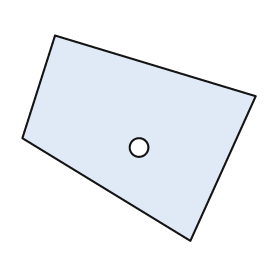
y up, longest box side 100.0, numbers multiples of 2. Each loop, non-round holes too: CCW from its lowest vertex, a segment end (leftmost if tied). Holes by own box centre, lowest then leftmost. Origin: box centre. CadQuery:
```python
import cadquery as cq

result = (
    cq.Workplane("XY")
    .moveTo(22.0, -44.0)
    .lineTo(50.0, 18.0)
    .lineTo(-36.0, 44.0)
    .lineTo(-50.0, 0.0)
    .close()
    .moveTo(0.0, -4.0)
    .circle(4.0)
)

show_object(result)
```